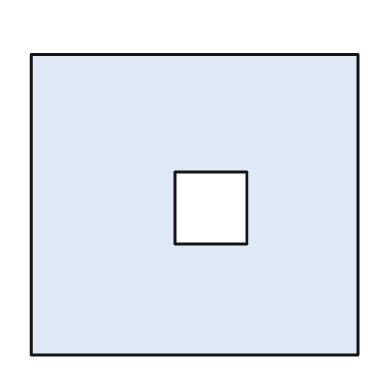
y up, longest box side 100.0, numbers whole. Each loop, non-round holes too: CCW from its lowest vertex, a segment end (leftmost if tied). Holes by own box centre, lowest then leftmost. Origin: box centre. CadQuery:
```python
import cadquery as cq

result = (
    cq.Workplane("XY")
    .moveTo(-50.0, -46.0)
    .lineTo(50.0, -46.0)
    .lineTo(50.0, 46.0)
    .lineTo(-50.0, 46.0)
    .close()
    .moveTo(-6.0, -12.0)
    .lineTo(16.0, -12.0)
    .lineTo(16.0, 10.0)
    .lineTo(-6.0, 10.0)
    .close()
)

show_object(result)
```